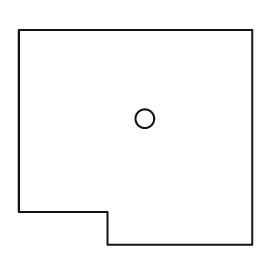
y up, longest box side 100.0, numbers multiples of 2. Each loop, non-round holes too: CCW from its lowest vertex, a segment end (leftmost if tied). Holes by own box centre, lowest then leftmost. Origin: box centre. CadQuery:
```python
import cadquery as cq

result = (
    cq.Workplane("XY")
    .moveTo(-12.0, -46.0)
    .lineTo(50.0, -46.0)
    .lineTo(50.0, 46.0)
    .lineTo(-50.0, 46.0)
    .lineTo(-50.0, -32.0)
    .lineTo(-12.0, -32.0)
    .close()
    .moveTo(4.0, 8.0)
    .circle(4.0)
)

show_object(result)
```